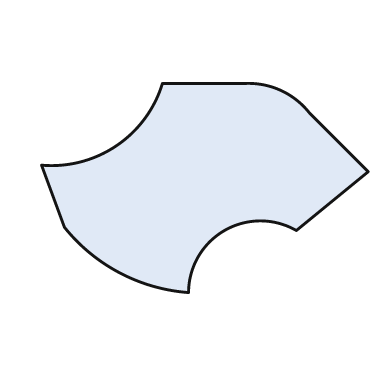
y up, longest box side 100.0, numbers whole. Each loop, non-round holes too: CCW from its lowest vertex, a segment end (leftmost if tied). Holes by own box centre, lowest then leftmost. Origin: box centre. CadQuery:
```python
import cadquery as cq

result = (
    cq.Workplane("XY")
    .moveTo(-5.0, -32.0)
    .threePointArc((6.0, -13.0), (28.0, -13.0))
    .lineTo(50.0, 5.0)
    .lineTo(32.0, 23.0)
    .threePointArc((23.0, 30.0), (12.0, 32.0))
    .lineTo(-13.0, 32.0)
    .threePointArc((-27.0, 13.0), (-50.0, 7.0))
    .lineTo(-43.0, -12.0)
    .threePointArc((-26.0, -26.0), (-5.0, -32.0))
    .close()
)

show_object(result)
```